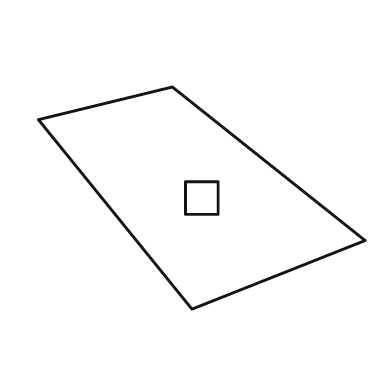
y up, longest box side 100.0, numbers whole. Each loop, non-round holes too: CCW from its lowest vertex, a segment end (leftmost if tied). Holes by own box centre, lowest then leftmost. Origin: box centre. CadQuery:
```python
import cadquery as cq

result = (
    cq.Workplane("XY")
    .moveTo(-3.0, -34.0)
    .lineTo(50.0, -13.0)
    .lineTo(-9.0, 34.0)
    .lineTo(-50.0, 24.0)
    .close()
    .moveTo(-5.0, -5.0)
    .lineTo(5.0, -5.0)
    .lineTo(5.0, 5.0)
    .lineTo(-5.0, 5.0)
    .close()
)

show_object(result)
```